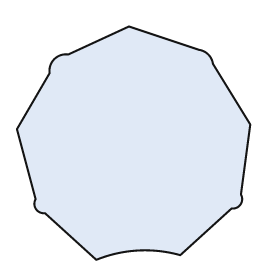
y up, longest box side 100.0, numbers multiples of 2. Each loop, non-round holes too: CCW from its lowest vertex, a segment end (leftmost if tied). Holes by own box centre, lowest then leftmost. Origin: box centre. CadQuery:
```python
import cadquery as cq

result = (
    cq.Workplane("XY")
    .moveTo(-16.0, -50.0)
    .threePointArc((2.0, -46.0), (20.0, -48.0))
    .lineTo(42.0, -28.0)
    .threePointArc((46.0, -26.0), (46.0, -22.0))
    .lineTo(50.0, 8.0)
    .lineTo(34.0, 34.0)
    .threePointArc((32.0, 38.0), (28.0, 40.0))
    .lineTo(-2.0, 50.0)
    .lineTo(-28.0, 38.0)
    .threePointArc((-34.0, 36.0), (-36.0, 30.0))
    .lineTo(-50.0, 6.0)
    .lineTo(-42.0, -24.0)
    .threePointArc((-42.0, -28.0), (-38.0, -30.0))
    .close()
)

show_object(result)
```